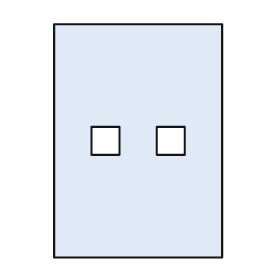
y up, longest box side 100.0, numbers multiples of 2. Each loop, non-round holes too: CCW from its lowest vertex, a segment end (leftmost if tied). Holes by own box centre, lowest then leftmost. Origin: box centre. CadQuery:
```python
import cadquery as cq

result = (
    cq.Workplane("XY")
    .moveTo(-36.0, -50.0)
    .lineTo(36.0, -50.0)
    .lineTo(36.0, 50.0)
    .lineTo(-36.0, 50.0)
    .close()
    .moveTo(-20.0, -6.0)
    .lineTo(-8.0, -6.0)
    .lineTo(-8.0, 6.0)
    .lineTo(-20.0, 6.0)
    .close()
    .moveTo(8.0, -6.0)
    .lineTo(20.0, -6.0)
    .lineTo(20.0, 6.0)
    .lineTo(8.0, 6.0)
    .close()
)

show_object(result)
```